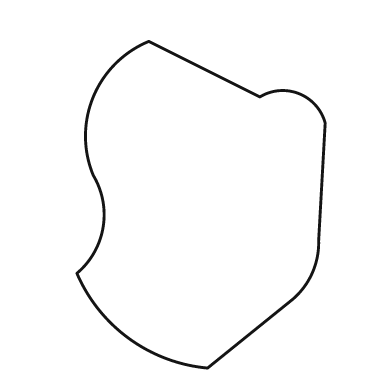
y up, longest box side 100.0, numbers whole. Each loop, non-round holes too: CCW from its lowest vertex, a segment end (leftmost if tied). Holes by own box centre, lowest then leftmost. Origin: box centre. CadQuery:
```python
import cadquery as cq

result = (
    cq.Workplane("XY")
    .moveTo(2.0, -50.0)
    .lineTo(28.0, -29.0)
    .threePointArc((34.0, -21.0), (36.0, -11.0))
    .lineTo(38.0, 25.0)
    .threePointArc((30.0, 34.0), (18.0, 33.0))
    .lineTo(-16.0, 50.0)
    .threePointArc((-33.0, 33.0), (-33.0, 9.0))
    .threePointArc((-30.0, -7.0), (-38.0, -21.0))
    .threePointArc((-22.0, -41.0), (2.0, -50.0))
    .close()
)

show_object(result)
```